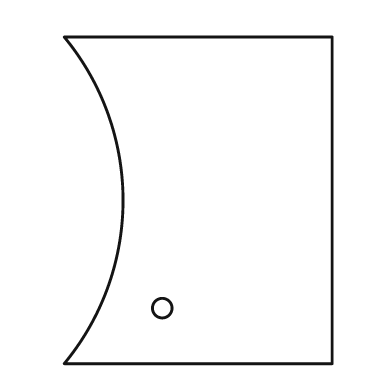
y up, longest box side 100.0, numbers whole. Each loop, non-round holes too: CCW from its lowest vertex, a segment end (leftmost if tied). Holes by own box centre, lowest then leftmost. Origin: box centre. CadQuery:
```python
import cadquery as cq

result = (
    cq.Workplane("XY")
    .moveTo(-41.0, -50.0)
    .lineTo(41.0, -50.0)
    .lineTo(41.0, 50.0)
    .lineTo(-41.0, 50.0)
    .threePointArc((-23.0, 0.0), (-41.0, -50.0))
    .close()
    .moveTo(-11.0, -33.0)
    .circle(3.0)
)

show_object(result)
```